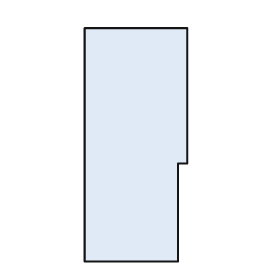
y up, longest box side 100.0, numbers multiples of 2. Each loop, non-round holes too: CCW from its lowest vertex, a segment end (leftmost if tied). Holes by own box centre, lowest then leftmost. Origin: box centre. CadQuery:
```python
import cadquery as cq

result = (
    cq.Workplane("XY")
    .moveTo(-22.0, -50.0)
    .lineTo(18.0, -50.0)
    .lineTo(18.0, -8.0)
    .lineTo(22.0, -8.0)
    .lineTo(22.0, 50.0)
    .lineTo(-22.0, 50.0)
    .close()
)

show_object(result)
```